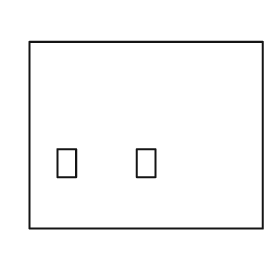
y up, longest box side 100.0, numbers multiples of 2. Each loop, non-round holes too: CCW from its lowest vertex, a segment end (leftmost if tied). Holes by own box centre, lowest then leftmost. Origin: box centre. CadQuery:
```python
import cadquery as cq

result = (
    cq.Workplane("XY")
    .moveTo(-50.0, -40.0)
    .lineTo(50.0, -40.0)
    .lineTo(50.0, 40.0)
    .lineTo(-50.0, 40.0)
    .close()
    .moveTo(-38.0, -18.0)
    .lineTo(-30.0, -18.0)
    .lineTo(-30.0, -6.0)
    .lineTo(-38.0, -6.0)
    .close()
    .moveTo(-4.0, -18.0)
    .lineTo(4.0, -18.0)
    .lineTo(4.0, -6.0)
    .lineTo(-4.0, -6.0)
    .close()
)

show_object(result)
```